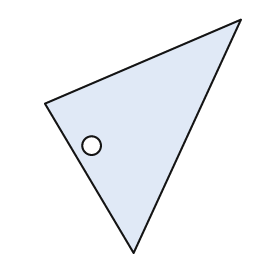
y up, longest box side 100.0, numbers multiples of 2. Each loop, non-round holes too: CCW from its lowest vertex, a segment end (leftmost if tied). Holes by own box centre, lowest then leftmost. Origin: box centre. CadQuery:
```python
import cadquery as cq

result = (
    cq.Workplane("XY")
    .moveTo(-4.0, -50.0)
    .lineTo(42.0, 50.0)
    .lineTo(-42.0, 14.0)
    .close()
    .moveTo(-22.0, -4.0)
    .circle(4.0)
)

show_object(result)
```